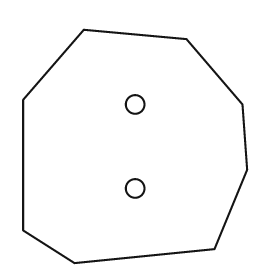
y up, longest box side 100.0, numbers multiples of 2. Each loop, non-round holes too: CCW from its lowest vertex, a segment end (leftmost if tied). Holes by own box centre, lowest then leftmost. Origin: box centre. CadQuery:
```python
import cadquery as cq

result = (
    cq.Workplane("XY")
    .moveTo(-26.0, -50.0)
    .lineTo(34.0, -44.0)
    .lineTo(48.0, -10.0)
    .lineTo(46.0, 18.0)
    .lineTo(22.0, 46.0)
    .lineTo(-22.0, 50.0)
    .lineTo(-48.0, 20.0)
    .lineTo(-48.0, -36.0)
    .close()
    .moveTo(0.0, -18.0)
    .circle(4.0)
    .moveTo(0.0, 18.0)
    .circle(4.0)
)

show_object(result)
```